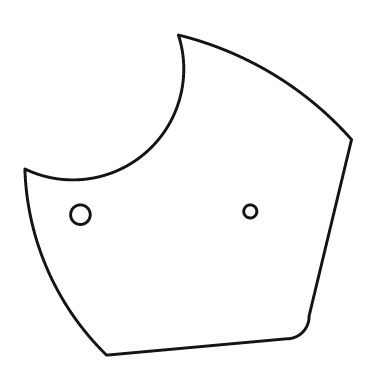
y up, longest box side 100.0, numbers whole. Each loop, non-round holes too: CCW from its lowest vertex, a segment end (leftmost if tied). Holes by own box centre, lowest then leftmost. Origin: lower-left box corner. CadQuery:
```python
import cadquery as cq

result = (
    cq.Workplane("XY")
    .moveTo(25.0, 0.0)
    .lineTo(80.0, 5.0)
    .threePointArc((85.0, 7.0), (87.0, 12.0))
    .lineTo(100.0, 66.0)
    .threePointArc((76.0, 86.0), (47.0, 98.0))
    .threePointArc((37.0, 62.0), (0.0, 57.0))
    .threePointArc((7.0, 26.0), (25.0, 0.0))
    .close()
    .moveTo(17.0, 43.0)
    .circle(3.0)
    .moveTo(69.0, 44.0)
    .circle(2.0)
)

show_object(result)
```